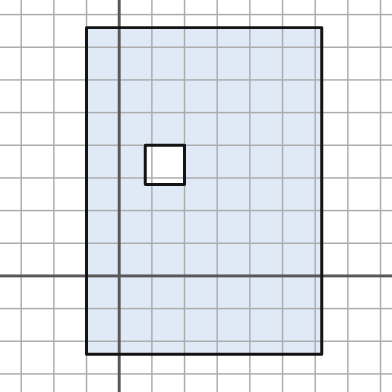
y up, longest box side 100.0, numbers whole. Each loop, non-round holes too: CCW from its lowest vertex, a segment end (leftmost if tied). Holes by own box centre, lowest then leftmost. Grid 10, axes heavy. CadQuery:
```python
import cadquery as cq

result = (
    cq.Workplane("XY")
    .moveTo(-10.0, -24.0)
    .lineTo(62.0, -24.0)
    .lineTo(62.0, 76.0)
    .lineTo(-10.0, 76.0)
    .close()
    .moveTo(8.0, 28.0)
    .lineTo(20.0, 28.0)
    .lineTo(20.0, 40.0)
    .lineTo(8.0, 40.0)
    .close()
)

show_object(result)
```